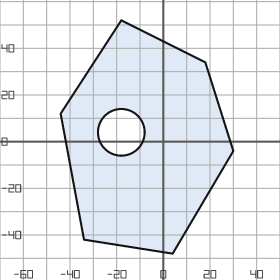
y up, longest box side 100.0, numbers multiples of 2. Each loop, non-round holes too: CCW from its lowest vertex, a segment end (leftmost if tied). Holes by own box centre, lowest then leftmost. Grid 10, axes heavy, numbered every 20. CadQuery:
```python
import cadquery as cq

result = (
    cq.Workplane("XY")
    .moveTo(4.0, -48.0)
    .lineTo(30.0, -4.0)
    .lineTo(18.0, 34.0)
    .lineTo(-18.0, 52.0)
    .lineTo(-44.0, 12.0)
    .lineTo(-34.0, -42.0)
    .close()
    .moveTo(-18.0, 4.0)
    .circle(10.0)
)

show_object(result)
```